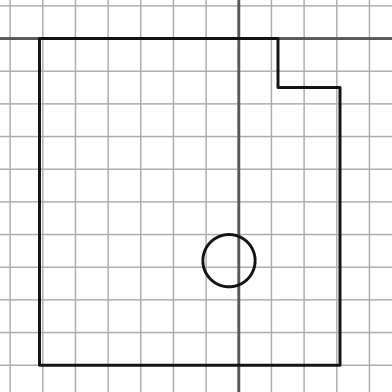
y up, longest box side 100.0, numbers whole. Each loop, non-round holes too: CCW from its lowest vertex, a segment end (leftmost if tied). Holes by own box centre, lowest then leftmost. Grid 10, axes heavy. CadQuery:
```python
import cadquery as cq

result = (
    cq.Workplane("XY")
    .moveTo(-61.0, -100.0)
    .lineTo(31.0, -100.0)
    .lineTo(31.0, -15.0)
    .lineTo(12.0, -15.0)
    .lineTo(12.0, 0.0)
    .lineTo(-61.0, 0.0)
    .close()
    .moveTo(-3.0, -68.0)
    .circle(8.0)
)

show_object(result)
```